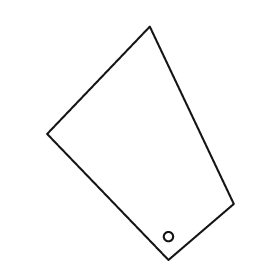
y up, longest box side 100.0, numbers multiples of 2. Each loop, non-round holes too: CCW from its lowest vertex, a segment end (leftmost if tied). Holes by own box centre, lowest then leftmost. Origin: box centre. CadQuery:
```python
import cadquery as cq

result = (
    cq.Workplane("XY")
    .moveTo(12.0, -50.0)
    .lineTo(40.0, -26.0)
    .lineTo(4.0, 50.0)
    .lineTo(-40.0, 4.0)
    .close()
    .moveTo(12.0, -40.0)
    .circle(2.0)
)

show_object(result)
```